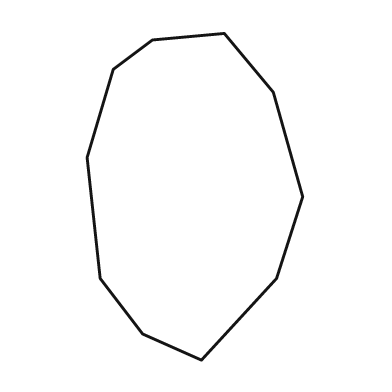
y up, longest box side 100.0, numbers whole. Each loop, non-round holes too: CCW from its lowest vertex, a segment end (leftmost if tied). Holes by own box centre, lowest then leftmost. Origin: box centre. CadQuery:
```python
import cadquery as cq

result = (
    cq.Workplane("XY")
    .moveTo(2.0, -50.0)
    .lineTo(25.0, -25.0)
    .lineTo(33.0, 0.0)
    .lineTo(24.0, 32.0)
    .lineTo(9.0, 50.0)
    .lineTo(-13.0, 48.0)
    .lineTo(-25.0, 39.0)
    .lineTo(-33.0, 12.0)
    .lineTo(-29.0, -25.0)
    .lineTo(-16.0, -42.0)
    .close()
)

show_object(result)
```